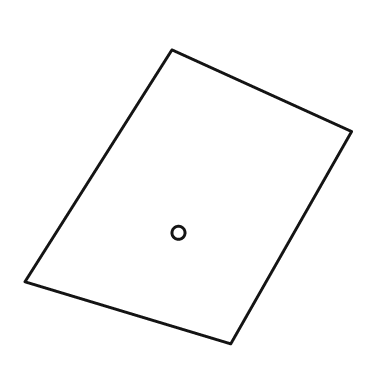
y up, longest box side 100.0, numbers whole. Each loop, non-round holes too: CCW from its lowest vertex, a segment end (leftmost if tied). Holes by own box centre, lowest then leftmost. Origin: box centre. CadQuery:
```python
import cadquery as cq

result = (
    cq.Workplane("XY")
    .moveTo(13.0, -45.0)
    .lineTo(50.0, 20.0)
    .lineTo(-5.0, 45.0)
    .lineTo(-50.0, -26.0)
    .close()
    .moveTo(-3.0, -11.0)
    .circle(2.0)
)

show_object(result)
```